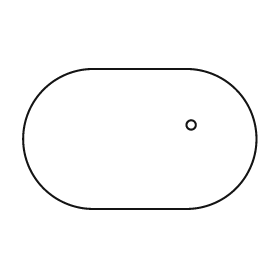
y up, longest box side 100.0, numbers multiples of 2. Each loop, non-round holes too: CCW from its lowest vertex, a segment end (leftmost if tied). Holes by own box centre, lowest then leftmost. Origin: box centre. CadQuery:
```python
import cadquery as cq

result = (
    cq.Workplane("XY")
    .moveTo(-20.0, -30.0)
    .lineTo(20.0, -30.0)
    .threePointArc((50.0, 0.0), (20.0, 30.0))
    .lineTo(-20.0, 30.0)
    .threePointArc((-50.0, 0.0), (-20.0, -30.0))
    .close()
    .moveTo(22.0, 6.0)
    .circle(2.0)
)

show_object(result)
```